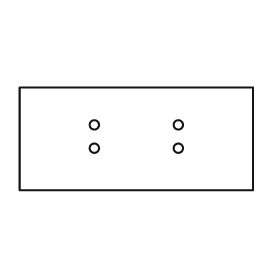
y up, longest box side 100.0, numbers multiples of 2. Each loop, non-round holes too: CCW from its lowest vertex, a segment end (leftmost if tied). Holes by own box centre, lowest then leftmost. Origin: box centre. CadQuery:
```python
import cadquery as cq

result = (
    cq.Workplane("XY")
    .moveTo(-50.0, -22.0)
    .lineTo(50.0, -22.0)
    .lineTo(50.0, 22.0)
    .lineTo(-50.0, 22.0)
    .close()
    .moveTo(-18.0, -4.0)
    .circle(2.0)
    .moveTo(18.0, -4.0)
    .circle(2.0)
    .moveTo(-18.0, 6.0)
    .circle(2.0)
    .moveTo(18.0, 6.0)
    .circle(2.0)
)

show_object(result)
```